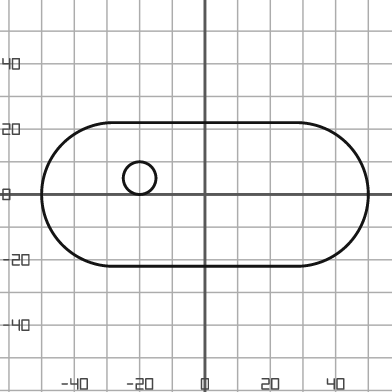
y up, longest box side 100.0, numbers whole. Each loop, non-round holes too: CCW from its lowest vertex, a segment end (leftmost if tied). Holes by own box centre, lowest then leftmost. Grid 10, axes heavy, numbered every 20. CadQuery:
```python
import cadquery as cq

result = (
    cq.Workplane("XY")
    .moveTo(-28.0, -22.0)
    .lineTo(28.0, -22.0)
    .threePointArc((50.0, 0.0), (28.0, 22.0))
    .lineTo(-28.0, 22.0)
    .threePointArc((-50.0, 0.0), (-28.0, -22.0))
    .close()
    .moveTo(-20.0, 5.0)
    .circle(5.0)
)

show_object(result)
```